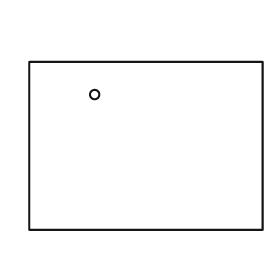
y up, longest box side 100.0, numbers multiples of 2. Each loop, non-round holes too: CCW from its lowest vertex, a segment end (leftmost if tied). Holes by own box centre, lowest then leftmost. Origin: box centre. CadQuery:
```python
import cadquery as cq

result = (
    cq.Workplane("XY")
    .moveTo(-50.0, -36.0)
    .lineTo(50.0, -36.0)
    .lineTo(50.0, 36.0)
    .lineTo(-50.0, 36.0)
    .close()
    .moveTo(-22.0, 22.0)
    .circle(2.0)
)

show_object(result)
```